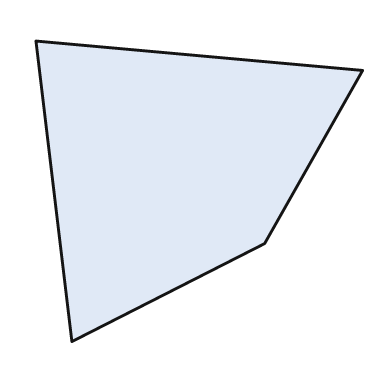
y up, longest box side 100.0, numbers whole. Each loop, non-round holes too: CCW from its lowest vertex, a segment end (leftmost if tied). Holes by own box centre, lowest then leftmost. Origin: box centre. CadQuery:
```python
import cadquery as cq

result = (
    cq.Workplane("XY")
    .moveTo(-39.0, -46.0)
    .lineTo(20.0, -16.0)
    .lineTo(50.0, 37.0)
    .lineTo(-50.0, 46.0)
    .close()
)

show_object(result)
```